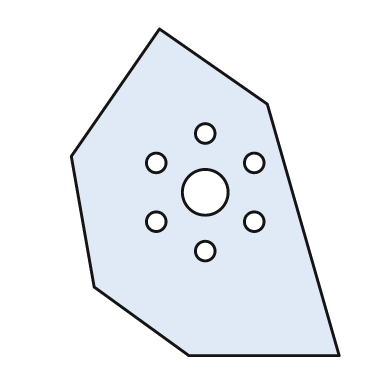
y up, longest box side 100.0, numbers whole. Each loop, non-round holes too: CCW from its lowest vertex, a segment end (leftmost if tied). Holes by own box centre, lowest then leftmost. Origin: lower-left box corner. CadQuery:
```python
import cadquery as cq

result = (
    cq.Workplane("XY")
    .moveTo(36.0, 0.0)
    .lineTo(82.0, 0.0)
    .lineTo(60.0, 77.0)
    .lineTo(27.0, 100.0)
    .lineTo(0.0, 61.0)
    .lineTo(7.0, 21.0)
    .close()
    .moveTo(41.0, 32.0)
    .circle(3.0)
    .moveTo(26.0, 41.0)
    .circle(3.0)
    .moveTo(56.0, 41.0)
    .circle(3.0)
    .moveTo(41.0, 50.0)
    .circle(7.0)
    .moveTo(26.0, 59.0)
    .circle(3.0)
    .moveTo(56.0, 59.0)
    .circle(3.0)
    .moveTo(41.0, 68.0)
    .circle(3.0)
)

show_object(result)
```